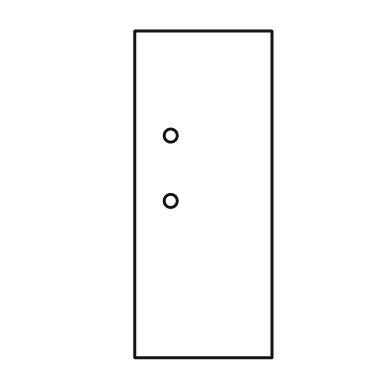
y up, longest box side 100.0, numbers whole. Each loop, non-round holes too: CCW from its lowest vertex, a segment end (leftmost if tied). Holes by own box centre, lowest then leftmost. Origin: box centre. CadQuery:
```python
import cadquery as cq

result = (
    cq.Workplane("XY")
    .moveTo(-21.0, -50.0)
    .lineTo(21.0, -50.0)
    .lineTo(21.0, 50.0)
    .lineTo(-21.0, 50.0)
    .close()
    .moveTo(-10.0, -2.0)
    .circle(2.0)
    .moveTo(-10.0, 18.0)
    .circle(2.0)
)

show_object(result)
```